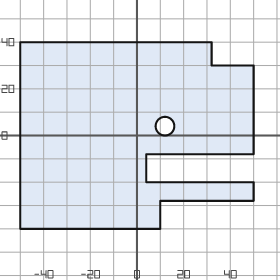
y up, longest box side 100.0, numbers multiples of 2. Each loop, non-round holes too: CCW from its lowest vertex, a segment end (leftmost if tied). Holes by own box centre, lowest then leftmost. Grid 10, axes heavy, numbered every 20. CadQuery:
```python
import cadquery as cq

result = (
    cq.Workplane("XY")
    .moveTo(-50.0, -40.0)
    .lineTo(10.0, -40.0)
    .lineTo(10.0, -28.0)
    .lineTo(50.0, -28.0)
    .lineTo(50.0, -20.0)
    .lineTo(4.0, -20.0)
    .lineTo(4.0, -8.0)
    .lineTo(50.0, -8.0)
    .lineTo(50.0, 30.0)
    .lineTo(32.0, 30.0)
    .lineTo(32.0, 40.0)
    .lineTo(-50.0, 40.0)
    .close()
    .moveTo(12.0, 4.0)
    .circle(4.0)
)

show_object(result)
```